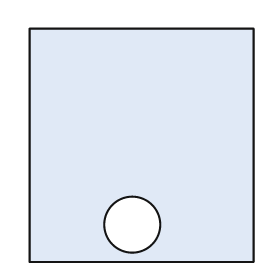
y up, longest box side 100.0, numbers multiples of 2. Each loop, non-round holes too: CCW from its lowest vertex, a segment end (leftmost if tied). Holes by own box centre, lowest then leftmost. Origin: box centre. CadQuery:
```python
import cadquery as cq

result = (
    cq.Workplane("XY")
    .moveTo(-48.0, -50.0)
    .lineTo(48.0, -50.0)
    .lineTo(48.0, 50.0)
    .lineTo(-48.0, 50.0)
    .close()
    .moveTo(-4.0, -34.0)
    .circle(12.0)
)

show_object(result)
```